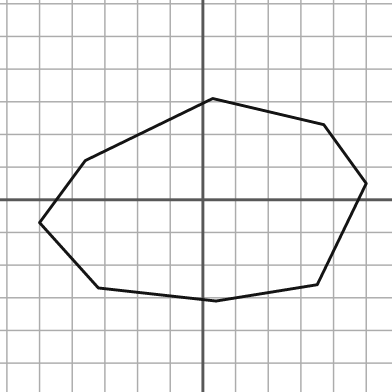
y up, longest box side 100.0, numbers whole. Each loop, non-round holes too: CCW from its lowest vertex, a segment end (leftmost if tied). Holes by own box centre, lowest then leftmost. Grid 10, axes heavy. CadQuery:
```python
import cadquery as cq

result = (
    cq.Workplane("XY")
    .moveTo(4.0, -31.0)
    .lineTo(35.0, -26.0)
    .lineTo(50.0, 5.0)
    .lineTo(37.0, 23.0)
    .lineTo(3.0, 31.0)
    .lineTo(-36.0, 12.0)
    .lineTo(-50.0, -7.0)
    .lineTo(-32.0, -27.0)
    .close()
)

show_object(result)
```